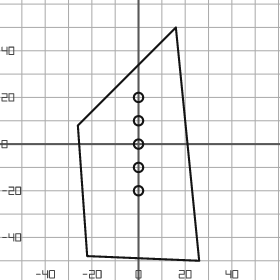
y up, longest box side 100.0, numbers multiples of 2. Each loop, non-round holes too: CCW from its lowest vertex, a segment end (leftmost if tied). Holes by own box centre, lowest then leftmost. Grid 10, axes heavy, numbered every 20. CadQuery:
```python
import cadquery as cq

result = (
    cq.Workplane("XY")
    .moveTo(26.0, -50.0)
    .lineTo(16.0, 50.0)
    .lineTo(-26.0, 8.0)
    .lineTo(-22.0, -48.0)
    .close()
    .moveTo(0.0, -20.0)
    .circle(2.0)
    .moveTo(0.0, -10.0)
    .circle(2.0)
    .moveTo(0.0, 0.0)
    .circle(2.0)
    .moveTo(0.0, 10.0)
    .circle(2.0)
    .moveTo(0.0, 20.0)
    .circle(2.0)
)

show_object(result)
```